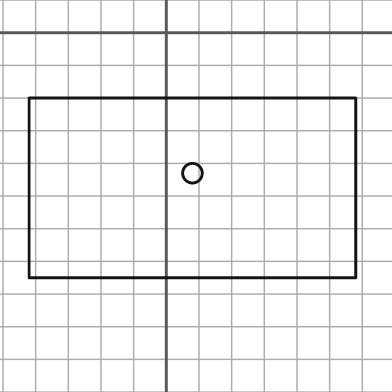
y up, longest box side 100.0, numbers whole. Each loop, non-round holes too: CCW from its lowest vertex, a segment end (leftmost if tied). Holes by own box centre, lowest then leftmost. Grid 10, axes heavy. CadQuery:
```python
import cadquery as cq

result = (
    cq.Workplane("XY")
    .moveTo(-42.0, -75.0)
    .lineTo(58.0, -75.0)
    .lineTo(58.0, -20.0)
    .lineTo(-42.0, -20.0)
    .close()
    .moveTo(8.0, -43.0)
    .circle(3.0)
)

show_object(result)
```